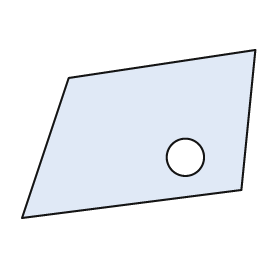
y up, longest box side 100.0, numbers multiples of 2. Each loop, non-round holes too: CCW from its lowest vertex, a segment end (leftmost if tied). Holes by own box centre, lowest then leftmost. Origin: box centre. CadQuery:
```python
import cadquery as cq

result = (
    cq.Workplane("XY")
    .moveTo(-50.0, -36.0)
    .lineTo(44.0, -24.0)
    .lineTo(50.0, 36.0)
    .lineTo(-30.0, 24.0)
    .close()
    .moveTo(20.0, -10.0)
    .circle(8.0)
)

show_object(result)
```